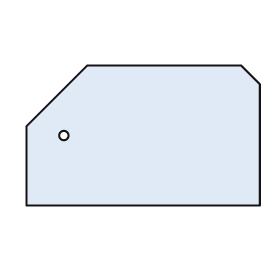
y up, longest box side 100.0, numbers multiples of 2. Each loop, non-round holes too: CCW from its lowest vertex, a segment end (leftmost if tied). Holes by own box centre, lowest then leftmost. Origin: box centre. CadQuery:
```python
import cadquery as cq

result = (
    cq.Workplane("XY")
    .moveTo(-50.0, -30.0)
    .lineTo(50.0, -30.0)
    .lineTo(50.0, 22.0)
    .lineTo(42.0, 30.0)
    .lineTo(-24.0, 30.0)
    .lineTo(-50.0, 4.0)
    .close()
    .moveTo(-34.0, 0.0)
    .circle(2.0)
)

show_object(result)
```